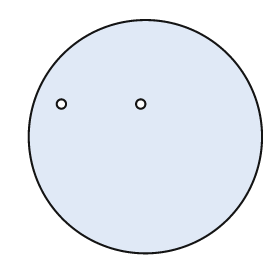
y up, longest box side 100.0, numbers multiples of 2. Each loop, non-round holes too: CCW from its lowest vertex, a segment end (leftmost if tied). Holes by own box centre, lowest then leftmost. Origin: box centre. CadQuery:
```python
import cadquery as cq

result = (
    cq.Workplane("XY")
    .moveTo(0.0, 0.0)
    .circle(50.0)
    .moveTo(-36.0, 14.0)
    .circle(2.0)
    .moveTo(-2.0, 14.0)
    .circle(2.0)
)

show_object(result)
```